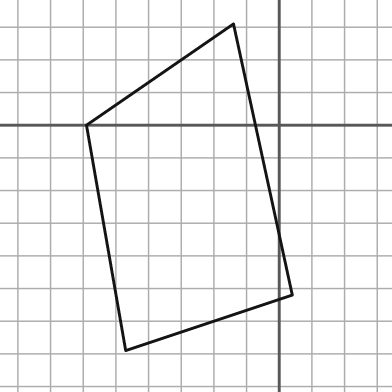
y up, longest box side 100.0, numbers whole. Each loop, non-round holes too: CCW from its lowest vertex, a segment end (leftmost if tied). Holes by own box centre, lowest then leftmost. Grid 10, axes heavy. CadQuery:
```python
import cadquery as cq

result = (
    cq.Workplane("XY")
    .moveTo(-47.0, -69.0)
    .lineTo(4.0, -52.0)
    .lineTo(-14.0, 31.0)
    .lineTo(-59.0, 0.0)
    .close()
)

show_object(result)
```